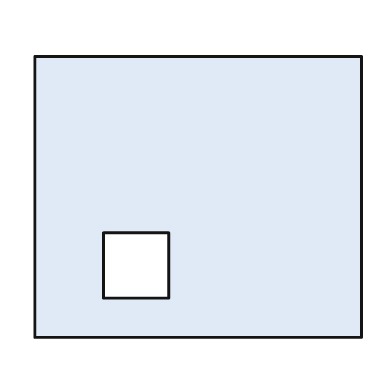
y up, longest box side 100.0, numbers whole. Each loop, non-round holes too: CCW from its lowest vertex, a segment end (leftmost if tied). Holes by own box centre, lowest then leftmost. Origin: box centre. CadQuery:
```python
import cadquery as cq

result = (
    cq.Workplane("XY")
    .moveTo(-50.0, -43.0)
    .lineTo(50.0, -43.0)
    .lineTo(50.0, 43.0)
    .lineTo(-50.0, 43.0)
    .close()
    .moveTo(-29.0, -31.0)
    .lineTo(-9.0, -31.0)
    .lineTo(-9.0, -11.0)
    .lineTo(-29.0, -11.0)
    .close()
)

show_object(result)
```